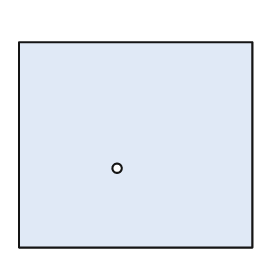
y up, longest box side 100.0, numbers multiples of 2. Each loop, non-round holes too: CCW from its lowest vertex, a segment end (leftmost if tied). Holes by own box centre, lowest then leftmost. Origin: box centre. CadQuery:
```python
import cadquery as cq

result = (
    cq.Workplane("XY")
    .moveTo(-50.0, -44.0)
    .lineTo(50.0, -44.0)
    .lineTo(50.0, 44.0)
    .lineTo(-50.0, 44.0)
    .close()
    .moveTo(-8.0, -10.0)
    .circle(2.0)
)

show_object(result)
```